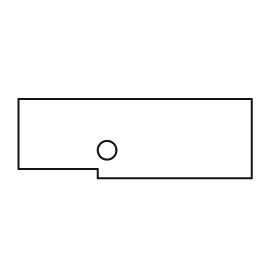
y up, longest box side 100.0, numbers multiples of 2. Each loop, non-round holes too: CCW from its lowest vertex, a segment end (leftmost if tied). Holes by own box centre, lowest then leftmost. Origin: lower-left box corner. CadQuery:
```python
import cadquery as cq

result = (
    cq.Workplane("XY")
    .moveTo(34.0, 0.0)
    .lineTo(100.0, 0.0)
    .lineTo(100.0, 34.0)
    .lineTo(0.0, 34.0)
    .lineTo(0.0, 4.0)
    .lineTo(34.0, 4.0)
    .close()
    .moveTo(38.0, 12.0)
    .circle(4.0)
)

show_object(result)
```